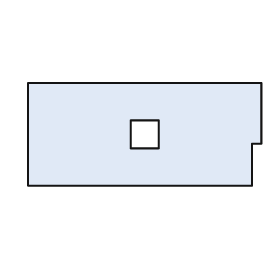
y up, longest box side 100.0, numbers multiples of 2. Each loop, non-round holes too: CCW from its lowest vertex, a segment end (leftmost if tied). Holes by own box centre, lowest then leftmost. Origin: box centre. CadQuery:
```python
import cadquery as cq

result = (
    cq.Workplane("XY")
    .moveTo(-50.0, -22.0)
    .lineTo(46.0, -22.0)
    .lineTo(46.0, -4.0)
    .lineTo(50.0, -4.0)
    .lineTo(50.0, 22.0)
    .lineTo(-50.0, 22.0)
    .close()
    .moveTo(-6.0, -6.0)
    .lineTo(6.0, -6.0)
    .lineTo(6.0, 6.0)
    .lineTo(-6.0, 6.0)
    .close()
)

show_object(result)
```